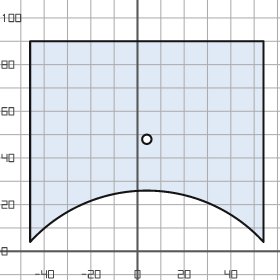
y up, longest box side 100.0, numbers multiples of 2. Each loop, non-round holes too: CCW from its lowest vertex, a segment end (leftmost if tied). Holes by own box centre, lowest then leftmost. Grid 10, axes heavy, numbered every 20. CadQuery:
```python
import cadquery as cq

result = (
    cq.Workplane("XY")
    .moveTo(-46.0, 4.0)
    .threePointArc((4.0, 26.0), (54.0, 4.0))
    .lineTo(54.0, 90.0)
    .lineTo(-46.0, 90.0)
    .close()
    .moveTo(4.0, 48.0)
    .circle(2.0)
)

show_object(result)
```